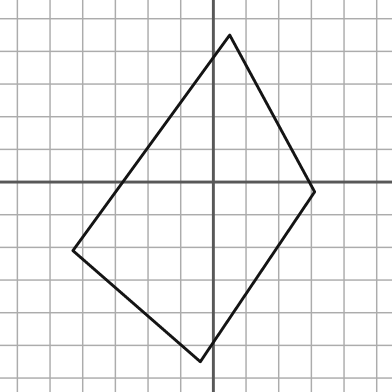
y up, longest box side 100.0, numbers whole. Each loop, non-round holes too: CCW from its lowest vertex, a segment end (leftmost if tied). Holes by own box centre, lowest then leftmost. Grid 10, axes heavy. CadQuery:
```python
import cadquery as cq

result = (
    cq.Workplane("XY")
    .moveTo(-4.0, -55.0)
    .lineTo(31.0, -3.0)
    .lineTo(5.0, 45.0)
    .lineTo(-43.0, -21.0)
    .close()
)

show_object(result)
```